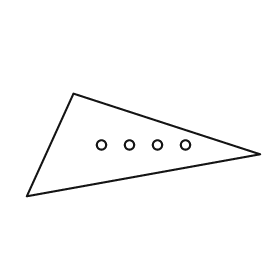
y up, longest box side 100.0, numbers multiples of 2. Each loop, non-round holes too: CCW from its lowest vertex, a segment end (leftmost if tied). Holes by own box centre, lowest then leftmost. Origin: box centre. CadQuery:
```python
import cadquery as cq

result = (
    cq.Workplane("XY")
    .moveTo(-50.0, -22.0)
    .lineTo(50.0, -4.0)
    .lineTo(-30.0, 22.0)
    .close()
    .moveTo(-18.0, 0.0)
    .circle(2.0)
    .moveTo(-6.0, 0.0)
    .circle(2.0)
    .moveTo(6.0, 0.0)
    .circle(2.0)
    .moveTo(18.0, 0.0)
    .circle(2.0)
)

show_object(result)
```